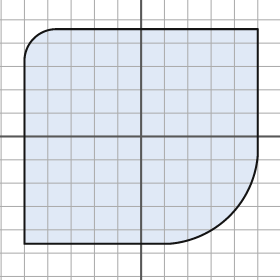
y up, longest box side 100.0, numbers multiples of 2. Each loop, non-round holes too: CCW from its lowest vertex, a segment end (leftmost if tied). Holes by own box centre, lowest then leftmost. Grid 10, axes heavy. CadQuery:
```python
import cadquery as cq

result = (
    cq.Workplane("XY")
    .moveTo(-50.0, -46.0)
    .lineTo(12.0, -46.0)
    .threePointArc((38.0, -34.0), (50.0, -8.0))
    .lineTo(50.0, 46.0)
    .lineTo(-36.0, 46.0)
    .threePointArc((-46.0, 42.0), (-50.0, 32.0))
    .close()
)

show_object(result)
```